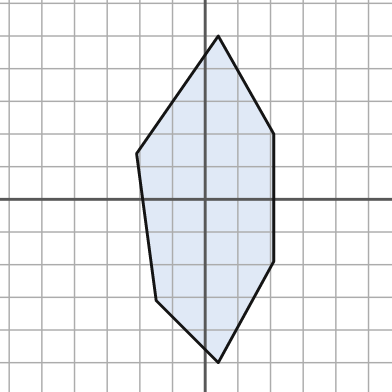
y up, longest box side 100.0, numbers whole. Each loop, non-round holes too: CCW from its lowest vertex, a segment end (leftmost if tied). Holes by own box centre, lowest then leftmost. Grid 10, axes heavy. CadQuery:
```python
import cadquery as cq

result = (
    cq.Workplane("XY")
    .moveTo(4.0, -50.0)
    .lineTo(21.0, -19.0)
    .lineTo(21.0, 20.0)
    .lineTo(4.0, 50.0)
    .lineTo(-21.0, 14.0)
    .lineTo(-15.0, -31.0)
    .close()
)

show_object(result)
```